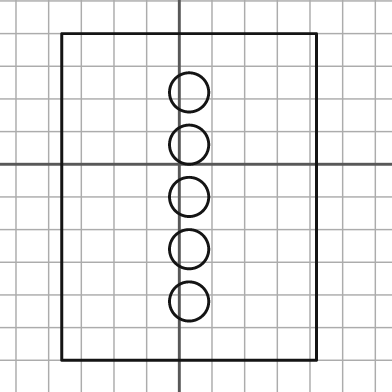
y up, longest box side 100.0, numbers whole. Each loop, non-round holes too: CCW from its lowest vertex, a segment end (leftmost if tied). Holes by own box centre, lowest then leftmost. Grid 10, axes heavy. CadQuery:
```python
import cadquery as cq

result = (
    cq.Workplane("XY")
    .moveTo(-36.0, -60.0)
    .lineTo(42.0, -60.0)
    .lineTo(42.0, 40.0)
    .lineTo(-36.0, 40.0)
    .close()
    .moveTo(3.0, -42.0)
    .circle(6.0)
    .moveTo(3.0, -26.0)
    .circle(6.0)
    .moveTo(3.0, -10.0)
    .circle(6.0)
    .moveTo(3.0, 6.0)
    .circle(6.0)
    .moveTo(3.0, 22.0)
    .circle(6.0)
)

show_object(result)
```